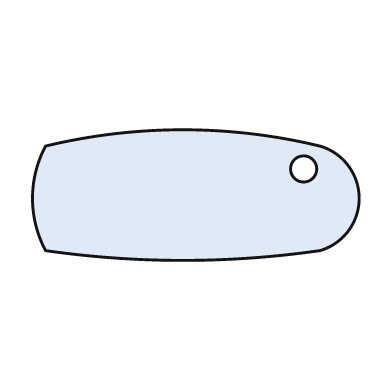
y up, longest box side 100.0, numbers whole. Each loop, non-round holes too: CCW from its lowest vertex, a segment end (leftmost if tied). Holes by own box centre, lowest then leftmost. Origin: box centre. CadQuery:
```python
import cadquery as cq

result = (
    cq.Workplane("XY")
    .moveTo(-46.0, -17.0)
    .threePointArc((-4.0, -20.0), (38.0, -17.0))
    .threePointArc((50.0, -1.0), (38.0, 15.0))
    .threePointArc((-4.0, 20.0), (-46.0, 15.0))
    .threePointArc((-50.0, -1.0), (-46.0, -17.0))
    .close()
    .moveTo(33.0, 8.0)
    .circle(4.0)
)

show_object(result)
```